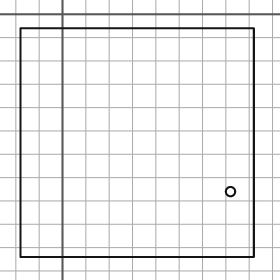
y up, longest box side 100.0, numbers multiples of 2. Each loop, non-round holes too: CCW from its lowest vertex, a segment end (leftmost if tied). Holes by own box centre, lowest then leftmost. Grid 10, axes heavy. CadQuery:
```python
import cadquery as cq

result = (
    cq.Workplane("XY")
    .moveTo(-18.0, -104.0)
    .lineTo(82.0, -104.0)
    .lineTo(82.0, -6.0)
    .lineTo(-18.0, -6.0)
    .close()
    .moveTo(72.0, -76.0)
    .circle(2.0)
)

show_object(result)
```